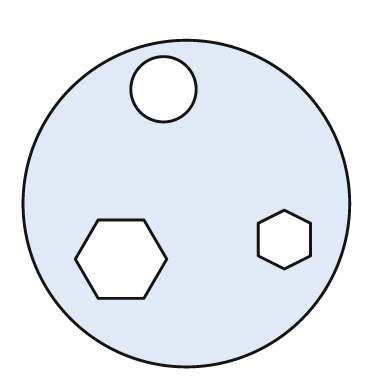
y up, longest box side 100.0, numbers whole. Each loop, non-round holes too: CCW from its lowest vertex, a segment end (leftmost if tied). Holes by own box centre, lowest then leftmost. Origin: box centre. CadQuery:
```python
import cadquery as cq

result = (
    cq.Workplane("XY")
    .moveTo(0.0, 0.0)
    .circle(50.0)
    .moveTo(-27.0, -29.0)
    .lineTo(-13.0, -29.0)
    .lineTo(-6.0, -17.0)
    .lineTo(-13.0, -5.0)
    .lineTo(-27.0, -5.0)
    .lineTo(-34.0, -17.0)
    .close()
    .moveTo(30.0, -20.0)
    .lineTo(38.0, -16.0)
    .lineTo(38.0, -6.0)
    .lineTo(30.0, -2.0)
    .lineTo(22.0, -6.0)
    .lineTo(22.0, -16.0)
    .close()
    .moveTo(-7.0, 35.0)
    .circle(10.0)
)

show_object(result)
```